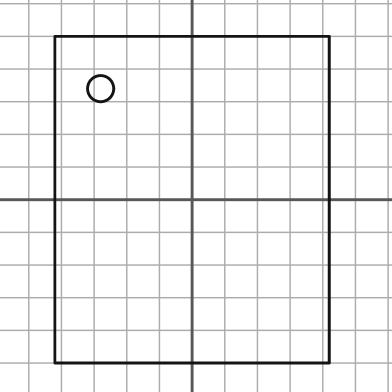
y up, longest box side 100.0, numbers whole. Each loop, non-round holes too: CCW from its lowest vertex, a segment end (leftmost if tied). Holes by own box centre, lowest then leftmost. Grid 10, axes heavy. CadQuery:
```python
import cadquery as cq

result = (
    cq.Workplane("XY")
    .moveTo(-42.0, -50.0)
    .lineTo(42.0, -50.0)
    .lineTo(42.0, 50.0)
    .lineTo(-42.0, 50.0)
    .close()
    .moveTo(-28.0, 34.0)
    .circle(4.0)
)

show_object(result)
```